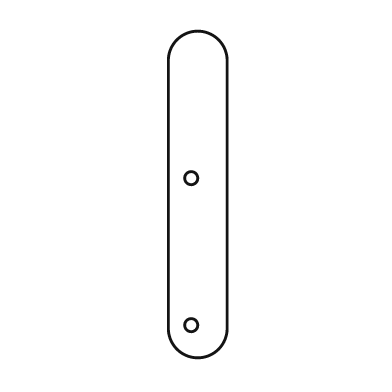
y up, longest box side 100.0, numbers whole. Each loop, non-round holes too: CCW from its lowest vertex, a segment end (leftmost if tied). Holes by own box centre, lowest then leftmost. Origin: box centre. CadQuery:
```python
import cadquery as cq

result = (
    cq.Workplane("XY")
    .moveTo(-9.0, -41.0)
    .threePointArc((0.0, -50.0), (9.0, -41.0))
    .lineTo(9.0, 41.0)
    .threePointArc((0.0, 50.0), (-9.0, 41.0))
    .close()
    .moveTo(-2.0, -40.0)
    .circle(2.0)
    .moveTo(-2.0, 5.0)
    .circle(2.0)
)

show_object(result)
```